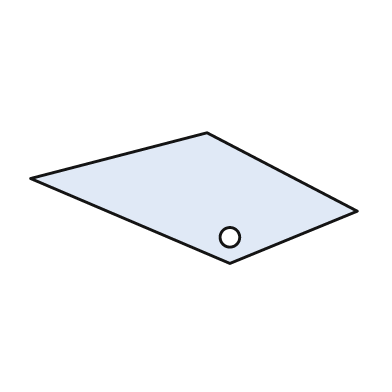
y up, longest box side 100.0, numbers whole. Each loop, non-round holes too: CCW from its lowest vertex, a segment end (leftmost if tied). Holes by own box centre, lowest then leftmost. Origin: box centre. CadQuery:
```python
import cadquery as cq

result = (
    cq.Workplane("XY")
    .moveTo(11.0, -20.0)
    .lineTo(50.0, -4.0)
    .lineTo(4.0, 20.0)
    .lineTo(-50.0, 6.0)
    .close()
    .moveTo(11.0, -12.0)
    .circle(3.0)
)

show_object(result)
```